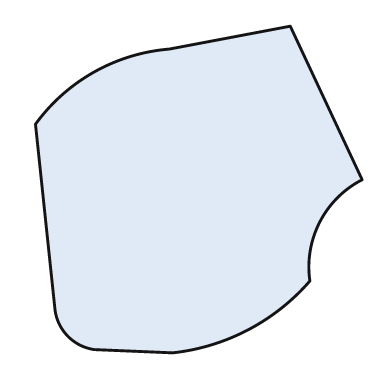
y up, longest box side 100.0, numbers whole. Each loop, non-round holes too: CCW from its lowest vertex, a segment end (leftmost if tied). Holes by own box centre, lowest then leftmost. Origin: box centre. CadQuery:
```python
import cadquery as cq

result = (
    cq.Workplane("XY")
    .moveTo(-8.0, -50.0)
    .threePointArc((15.0, -43.0), (34.0, -28.0))
    .threePointArc((37.0, -10.0), (50.0, 3.0))
    .lineTo(28.0, 50.0)
    .lineTo(-9.0, 43.0)
    .threePointArc((-32.0, 36.0), (-50.0, 20.0))
    .lineTo(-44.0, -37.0)
    .threePointArc((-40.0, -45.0), (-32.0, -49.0))
    .close()
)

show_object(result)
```